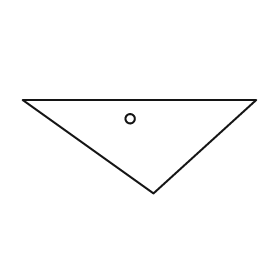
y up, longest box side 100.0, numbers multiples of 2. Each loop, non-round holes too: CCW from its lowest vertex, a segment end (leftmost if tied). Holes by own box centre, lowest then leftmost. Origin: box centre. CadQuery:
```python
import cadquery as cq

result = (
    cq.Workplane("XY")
    .moveTo(6.0, -20.0)
    .lineTo(50.0, 20.0)
    .lineTo(-50.0, 20.0)
    .close()
    .moveTo(-4.0, 12.0)
    .circle(2.0)
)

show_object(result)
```